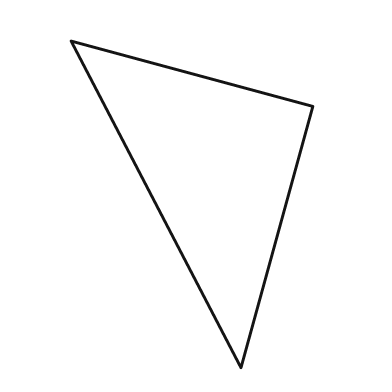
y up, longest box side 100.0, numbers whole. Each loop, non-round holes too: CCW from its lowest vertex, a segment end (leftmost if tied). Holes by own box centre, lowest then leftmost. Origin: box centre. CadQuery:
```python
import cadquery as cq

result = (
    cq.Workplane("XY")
    .moveTo(15.0, -50.0)
    .lineTo(37.0, 30.0)
    .lineTo(-37.0, 50.0)
    .close()
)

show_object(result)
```